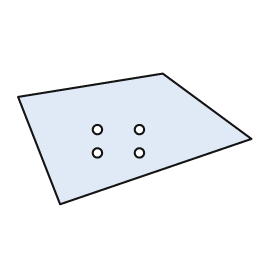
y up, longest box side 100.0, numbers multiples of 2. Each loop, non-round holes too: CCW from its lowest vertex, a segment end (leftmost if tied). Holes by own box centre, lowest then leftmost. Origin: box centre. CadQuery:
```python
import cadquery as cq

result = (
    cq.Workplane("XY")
    .moveTo(-32.0, -28.0)
    .lineTo(50.0, 0.0)
    .lineTo(12.0, 28.0)
    .lineTo(-50.0, 18.0)
    .close()
    .moveTo(-16.0, -6.0)
    .circle(2.0)
    .moveTo(2.0, -6.0)
    .circle(2.0)
    .moveTo(-16.0, 4.0)
    .circle(2.0)
    .moveTo(2.0, 4.0)
    .circle(2.0)
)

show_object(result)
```